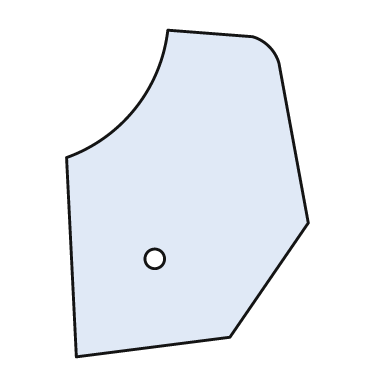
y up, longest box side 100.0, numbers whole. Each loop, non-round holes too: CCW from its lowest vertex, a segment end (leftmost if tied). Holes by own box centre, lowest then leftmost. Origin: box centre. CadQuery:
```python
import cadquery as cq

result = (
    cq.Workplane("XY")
    .moveTo(-34.0, -50.0)
    .lineTo(13.0, -44.0)
    .lineTo(37.0, -9.0)
    .lineTo(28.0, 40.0)
    .threePointArc((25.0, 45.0), (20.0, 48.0))
    .lineTo(-6.0, 50.0)
    .threePointArc((-16.0, 26.0), (-37.0, 11.0))
    .close()
    .moveTo(-10.0, -20.0)
    .circle(3.0)
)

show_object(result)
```